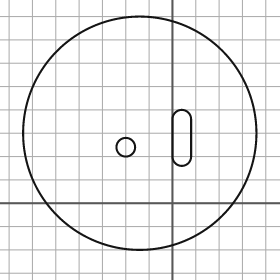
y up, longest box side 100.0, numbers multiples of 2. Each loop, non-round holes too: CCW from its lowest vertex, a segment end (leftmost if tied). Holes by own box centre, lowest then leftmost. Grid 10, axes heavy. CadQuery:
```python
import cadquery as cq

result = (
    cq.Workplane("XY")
    .moveTo(-14.0, 30.0)
    .circle(50.0)
    .moveTo(-20.0, 24.0)
    .circle(4.0)
    .moveTo(0.0, 20.0)
    .threePointArc((4.0, 16.0), (8.0, 20.0))
    .lineTo(8.0, 36.0)
    .threePointArc((4.0, 40.0), (0.0, 36.0))
    .close()
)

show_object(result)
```